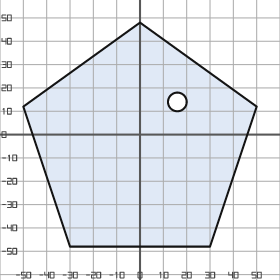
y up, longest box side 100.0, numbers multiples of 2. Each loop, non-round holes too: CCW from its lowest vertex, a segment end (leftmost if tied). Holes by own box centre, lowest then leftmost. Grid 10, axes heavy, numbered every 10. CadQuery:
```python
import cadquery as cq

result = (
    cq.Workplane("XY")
    .moveTo(-30.0, -48.0)
    .lineTo(30.0, -48.0)
    .lineTo(50.0, 12.0)
    .lineTo(0.0, 48.0)
    .lineTo(-50.0, 12.0)
    .close()
    .moveTo(16.0, 14.0)
    .circle(4.0)
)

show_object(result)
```